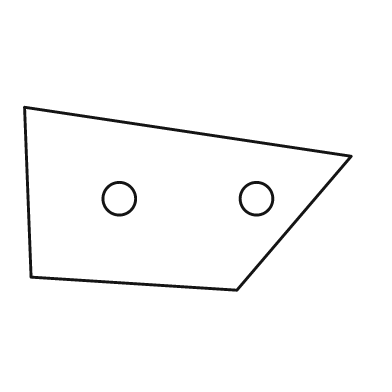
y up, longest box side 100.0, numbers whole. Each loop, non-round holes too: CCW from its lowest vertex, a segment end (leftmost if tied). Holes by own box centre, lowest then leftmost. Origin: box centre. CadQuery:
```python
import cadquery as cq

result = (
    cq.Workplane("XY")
    .moveTo(15.0, -28.0)
    .lineTo(50.0, 13.0)
    .lineTo(-50.0, 28.0)
    .lineTo(-48.0, -24.0)
    .close()
    .moveTo(-21.0, 0.0)
    .circle(5.0)
    .moveTo(21.0, 0.0)
    .circle(5.0)
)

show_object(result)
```